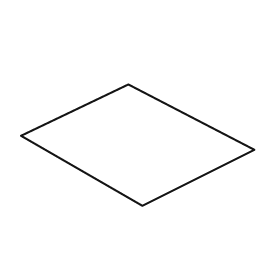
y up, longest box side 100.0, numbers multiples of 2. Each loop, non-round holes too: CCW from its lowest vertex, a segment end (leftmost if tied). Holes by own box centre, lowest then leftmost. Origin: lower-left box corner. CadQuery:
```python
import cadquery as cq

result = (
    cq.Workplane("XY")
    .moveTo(52.0, 0.0)
    .lineTo(100.0, 24.0)
    .lineTo(46.0, 52.0)
    .lineTo(0.0, 30.0)
    .close()
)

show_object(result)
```